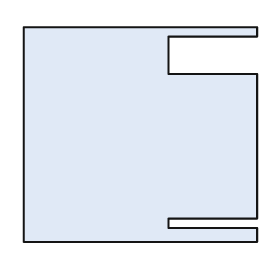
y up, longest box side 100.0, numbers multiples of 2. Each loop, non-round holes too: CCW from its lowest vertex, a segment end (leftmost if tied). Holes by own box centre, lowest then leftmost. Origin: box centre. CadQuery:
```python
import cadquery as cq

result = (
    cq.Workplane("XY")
    .moveTo(-50.0, -46.0)
    .lineTo(50.0, -46.0)
    .lineTo(50.0, -40.0)
    .lineTo(12.0, -40.0)
    .lineTo(12.0, -36.0)
    .lineTo(50.0, -36.0)
    .lineTo(50.0, 26.0)
    .lineTo(12.0, 26.0)
    .lineTo(12.0, 42.0)
    .lineTo(50.0, 42.0)
    .lineTo(50.0, 46.0)
    .lineTo(-50.0, 46.0)
    .close()
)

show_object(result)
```